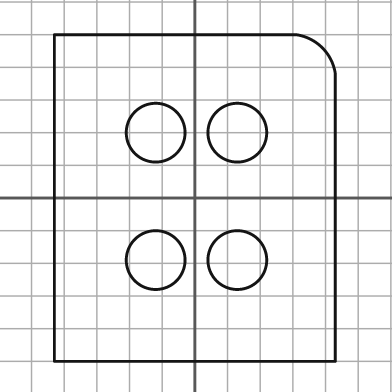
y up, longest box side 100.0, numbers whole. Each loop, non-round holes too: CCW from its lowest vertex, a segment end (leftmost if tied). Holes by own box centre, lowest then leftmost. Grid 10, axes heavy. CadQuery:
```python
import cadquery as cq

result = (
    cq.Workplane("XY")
    .moveTo(-43.0, -50.0)
    .lineTo(43.0, -50.0)
    .lineTo(43.0, 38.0)
    .threePointArc((39.0, 46.0), (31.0, 50.0))
    .lineTo(-43.0, 50.0)
    .close()
    .moveTo(-12.0, -19.0)
    .circle(9.0)
    .moveTo(13.0, -19.0)
    .circle(9.0)
    .moveTo(-12.0, 20.0)
    .circle(9.0)
    .moveTo(13.0, 20.0)
    .circle(9.0)
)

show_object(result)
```